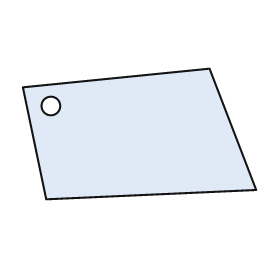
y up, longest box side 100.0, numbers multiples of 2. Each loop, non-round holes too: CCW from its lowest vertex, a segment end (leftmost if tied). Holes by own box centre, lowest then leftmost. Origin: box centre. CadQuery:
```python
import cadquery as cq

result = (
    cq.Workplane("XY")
    .moveTo(-40.0, -28.0)
    .lineTo(50.0, -24.0)
    .lineTo(30.0, 28.0)
    .lineTo(-50.0, 20.0)
    .close()
    .moveTo(-38.0, 12.0)
    .circle(4.0)
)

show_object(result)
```